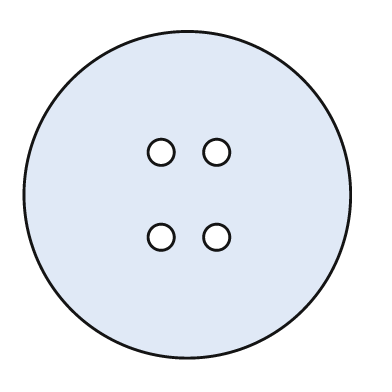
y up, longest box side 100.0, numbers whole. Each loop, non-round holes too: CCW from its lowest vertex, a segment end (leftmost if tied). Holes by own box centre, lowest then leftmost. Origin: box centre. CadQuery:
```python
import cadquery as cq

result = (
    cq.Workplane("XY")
    .moveTo(0.0, 0.0)
    .circle(50.0)
    .moveTo(-8.0, -13.0)
    .circle(4.0)
    .moveTo(9.0, -13.0)
    .circle(4.0)
    .moveTo(-8.0, 13.0)
    .circle(4.0)
    .moveTo(9.0, 13.0)
    .circle(4.0)
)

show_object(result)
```